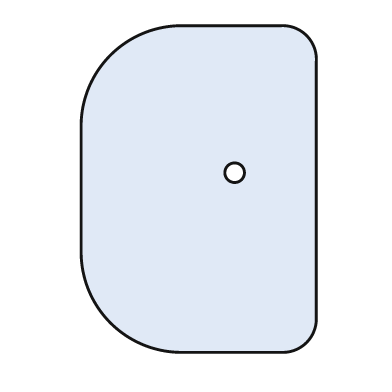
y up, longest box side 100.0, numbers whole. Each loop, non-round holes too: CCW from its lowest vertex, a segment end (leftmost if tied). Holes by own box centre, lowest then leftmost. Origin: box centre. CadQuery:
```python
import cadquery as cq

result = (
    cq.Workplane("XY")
    .moveTo(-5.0, -50.0)
    .lineTo(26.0, -50.0)
    .threePointArc((33.0, -47.0), (36.0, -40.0))
    .lineTo(36.0, 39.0)
    .threePointArc((33.0, 47.0), (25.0, 50.0))
    .lineTo(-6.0, 50.0)
    .threePointArc((-27.0, 41.0), (-36.0, 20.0))
    .lineTo(-36.0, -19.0)
    .threePointArc((-27.0, -41.0), (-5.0, -50.0))
    .close()
    .moveTo(11.0, 5.0)
    .circle(3.0)
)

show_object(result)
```